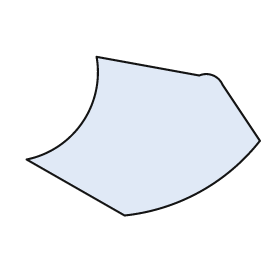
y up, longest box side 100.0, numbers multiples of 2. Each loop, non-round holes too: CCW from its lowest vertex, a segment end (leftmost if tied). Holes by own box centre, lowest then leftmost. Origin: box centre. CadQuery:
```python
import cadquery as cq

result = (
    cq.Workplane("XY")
    .moveTo(-8.0, -34.0)
    .threePointArc((24.0, -24.0), (50.0, -2.0))
    .lineTo(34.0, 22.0)
    .threePointArc((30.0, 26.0), (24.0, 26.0))
    .lineTo(-20.0, 34.0)
    .threePointArc((-26.0, 6.0), (-50.0, -10.0))
    .close()
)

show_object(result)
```